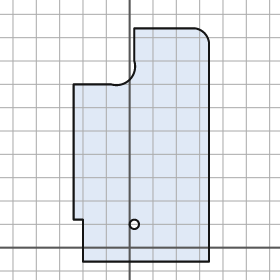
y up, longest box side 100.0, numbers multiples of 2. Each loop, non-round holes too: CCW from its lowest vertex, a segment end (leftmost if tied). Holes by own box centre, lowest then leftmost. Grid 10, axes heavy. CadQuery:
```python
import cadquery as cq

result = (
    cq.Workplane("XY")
    .moveTo(-20.0, -6.0)
    .lineTo(34.0, -6.0)
    .lineTo(34.0, 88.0)
    .threePointArc((32.0, 92.0), (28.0, 94.0))
    .lineTo(2.0, 94.0)
    .lineTo(2.0, 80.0)
    .threePointArc((0.0, 72.0), (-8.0, 70.0))
    .lineTo(-24.0, 70.0)
    .lineTo(-24.0, 12.0)
    .lineTo(-20.0, 12.0)
    .close()
    .moveTo(2.0, 10.0)
    .circle(2.0)
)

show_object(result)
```